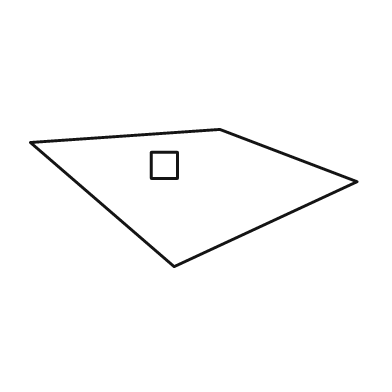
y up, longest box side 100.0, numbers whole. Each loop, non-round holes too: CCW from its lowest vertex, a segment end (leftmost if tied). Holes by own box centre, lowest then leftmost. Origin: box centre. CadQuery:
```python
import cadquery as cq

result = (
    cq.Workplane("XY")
    .moveTo(-6.0, -21.0)
    .lineTo(50.0, 5.0)
    .lineTo(8.0, 21.0)
    .lineTo(-50.0, 17.0)
    .close()
    .moveTo(-13.0, 6.0)
    .lineTo(-5.0, 6.0)
    .lineTo(-5.0, 14.0)
    .lineTo(-13.0, 14.0)
    .close()
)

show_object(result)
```